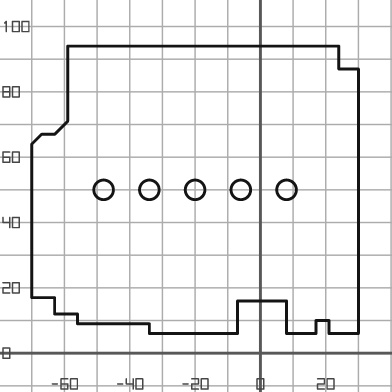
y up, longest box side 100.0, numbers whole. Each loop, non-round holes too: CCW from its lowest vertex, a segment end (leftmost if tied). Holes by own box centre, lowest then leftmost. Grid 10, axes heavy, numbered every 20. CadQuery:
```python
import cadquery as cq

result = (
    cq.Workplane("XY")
    .moveTo(-34.0, 6.0)
    .lineTo(-7.0, 6.0)
    .lineTo(-7.0, 16.0)
    .lineTo(8.0, 16.0)
    .lineTo(8.0, 6.0)
    .lineTo(17.0, 6.0)
    .lineTo(17.0, 10.0)
    .lineTo(21.0, 10.0)
    .lineTo(21.0, 6.0)
    .lineTo(30.0, 6.0)
    .lineTo(30.0, 87.0)
    .lineTo(24.0, 87.0)
    .lineTo(24.0, 94.0)
    .lineTo(-59.0, 94.0)
    .lineTo(-59.0, 71.0)
    .lineTo(-63.0, 67.0)
    .lineTo(-67.0, 67.0)
    .lineTo(-70.0, 64.0)
    .lineTo(-70.0, 17.0)
    .lineTo(-63.0, 17.0)
    .lineTo(-63.0, 12.0)
    .lineTo(-56.0, 12.0)
    .lineTo(-56.0, 9.0)
    .lineTo(-34.0, 9.0)
    .close()
    .moveTo(-48.0, 50.0)
    .circle(3.0)
    .moveTo(-34.0, 50.0)
    .circle(3.0)
    .moveTo(-20.0, 50.0)
    .circle(3.0)
    .moveTo(-6.0, 50.0)
    .circle(3.0)
    .moveTo(8.0, 50.0)
    .circle(3.0)
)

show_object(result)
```